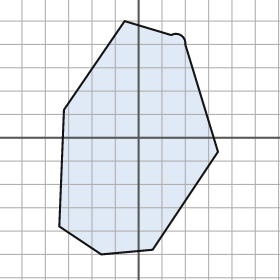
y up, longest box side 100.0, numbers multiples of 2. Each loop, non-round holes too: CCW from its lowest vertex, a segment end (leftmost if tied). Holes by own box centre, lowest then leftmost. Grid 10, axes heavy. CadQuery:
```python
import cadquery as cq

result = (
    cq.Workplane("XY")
    .moveTo(-16.0, -50.0)
    .lineTo(6.0, -48.0)
    .lineTo(34.0, -6.0)
    .lineTo(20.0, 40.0)
    .threePointArc((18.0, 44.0), (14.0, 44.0))
    .lineTo(-6.0, 50.0)
    .lineTo(-32.0, 12.0)
    .lineTo(-34.0, -38.0)
    .close()
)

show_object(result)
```